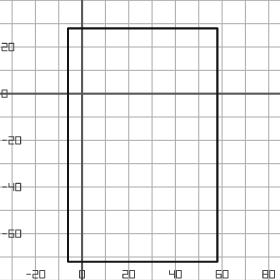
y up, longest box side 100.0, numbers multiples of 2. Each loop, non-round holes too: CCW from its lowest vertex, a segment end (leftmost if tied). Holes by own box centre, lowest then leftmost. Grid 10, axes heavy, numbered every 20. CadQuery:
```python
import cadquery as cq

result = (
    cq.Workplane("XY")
    .moveTo(-6.0, -72.0)
    .lineTo(58.0, -72.0)
    .lineTo(58.0, 28.0)
    .lineTo(-6.0, 28.0)
    .close()
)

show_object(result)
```